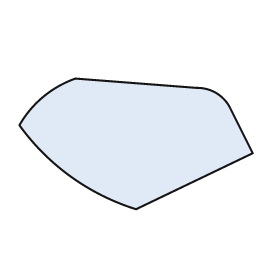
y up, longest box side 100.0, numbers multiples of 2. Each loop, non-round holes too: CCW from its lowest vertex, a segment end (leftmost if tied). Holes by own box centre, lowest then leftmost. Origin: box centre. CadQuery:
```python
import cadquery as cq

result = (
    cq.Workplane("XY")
    .moveTo(0.0, -28.0)
    .lineTo(50.0, -4.0)
    .lineTo(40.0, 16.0)
    .threePointArc((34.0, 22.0), (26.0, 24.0))
    .lineTo(-26.0, 28.0)
    .threePointArc((-40.0, 20.0), (-50.0, 8.0))
    .threePointArc((-28.0, -14.0), (0.0, -28.0))
    .close()
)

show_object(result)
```